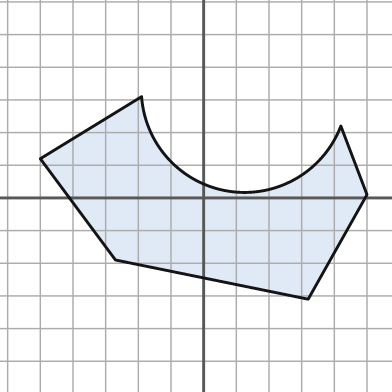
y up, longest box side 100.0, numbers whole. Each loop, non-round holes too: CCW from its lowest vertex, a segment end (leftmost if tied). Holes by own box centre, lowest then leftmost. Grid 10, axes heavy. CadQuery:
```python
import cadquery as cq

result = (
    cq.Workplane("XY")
    .moveTo(32.0, -31.0)
    .lineTo(50.0, 1.0)
    .lineTo(42.0, 22.0)
    .threePointArc((8.0, 2.0), (-19.0, 31.0))
    .lineTo(-50.0, 12.0)
    .lineTo(-27.0, -19.0)
    .close()
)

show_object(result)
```